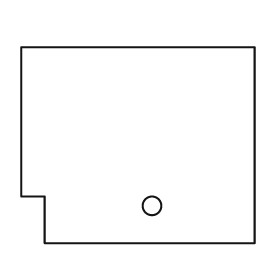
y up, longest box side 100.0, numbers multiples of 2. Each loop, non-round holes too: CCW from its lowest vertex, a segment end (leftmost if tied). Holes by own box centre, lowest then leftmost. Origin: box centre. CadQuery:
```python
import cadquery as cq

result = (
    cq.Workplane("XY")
    .moveTo(-40.0, -42.0)
    .lineTo(50.0, -42.0)
    .lineTo(50.0, 42.0)
    .lineTo(-50.0, 42.0)
    .lineTo(-50.0, -22.0)
    .lineTo(-40.0, -22.0)
    .close()
    .moveTo(6.0, -26.0)
    .circle(4.0)
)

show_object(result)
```